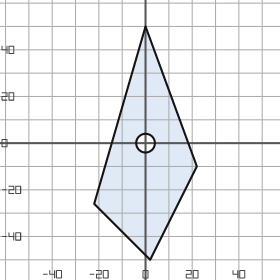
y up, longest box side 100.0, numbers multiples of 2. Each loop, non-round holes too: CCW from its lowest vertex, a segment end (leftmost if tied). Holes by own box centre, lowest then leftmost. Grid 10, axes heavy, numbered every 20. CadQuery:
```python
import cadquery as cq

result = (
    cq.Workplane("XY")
    .moveTo(2.0, -50.0)
    .lineTo(22.0, -10.0)
    .lineTo(0.0, 50.0)
    .lineTo(-22.0, -26.0)
    .close()
    .moveTo(0.0, 0.0)
    .circle(4.0)
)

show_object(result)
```